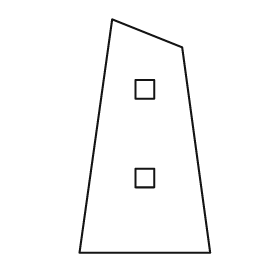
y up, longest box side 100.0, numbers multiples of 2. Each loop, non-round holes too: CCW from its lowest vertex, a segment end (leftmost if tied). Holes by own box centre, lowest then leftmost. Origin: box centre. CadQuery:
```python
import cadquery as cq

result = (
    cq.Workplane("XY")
    .moveTo(-28.0, -50.0)
    .lineTo(28.0, -50.0)
    .lineTo(16.0, 38.0)
    .lineTo(-14.0, 50.0)
    .close()
    .moveTo(-4.0, -22.0)
    .lineTo(4.0, -22.0)
    .lineTo(4.0, -14.0)
    .lineTo(-4.0, -14.0)
    .close()
    .moveTo(-4.0, 16.0)
    .lineTo(4.0, 16.0)
    .lineTo(4.0, 24.0)
    .lineTo(-4.0, 24.0)
    .close()
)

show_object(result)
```